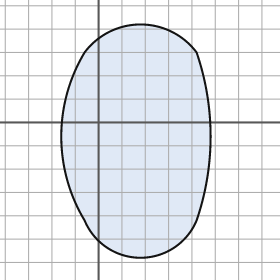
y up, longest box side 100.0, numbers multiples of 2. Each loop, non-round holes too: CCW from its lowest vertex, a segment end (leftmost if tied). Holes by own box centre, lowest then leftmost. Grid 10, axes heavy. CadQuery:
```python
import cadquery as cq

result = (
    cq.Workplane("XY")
    .moveTo(-6.0, -42.0)
    .threePointArc((18.0, -58.0), (42.0, -42.0))
    .threePointArc((48.0, -6.0), (42.0, 30.0))
    .threePointArc((18.0, 42.0), (-6.0, 30.0))
    .threePointArc((-16.0, -6.0), (-6.0, -42.0))
    .close()
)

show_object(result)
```